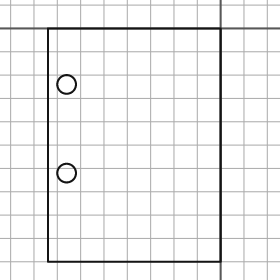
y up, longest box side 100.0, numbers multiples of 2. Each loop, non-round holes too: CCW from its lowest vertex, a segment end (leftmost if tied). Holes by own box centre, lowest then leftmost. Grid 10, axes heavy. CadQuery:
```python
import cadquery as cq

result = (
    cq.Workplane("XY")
    .moveTo(-74.0, -100.0)
    .lineTo(0.0, -100.0)
    .lineTo(0.0, 0.0)
    .lineTo(-74.0, 0.0)
    .close()
    .moveTo(-66.0, -62.0)
    .circle(4.0)
    .moveTo(-66.0, -24.0)
    .circle(4.0)
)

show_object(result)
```